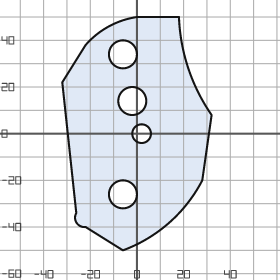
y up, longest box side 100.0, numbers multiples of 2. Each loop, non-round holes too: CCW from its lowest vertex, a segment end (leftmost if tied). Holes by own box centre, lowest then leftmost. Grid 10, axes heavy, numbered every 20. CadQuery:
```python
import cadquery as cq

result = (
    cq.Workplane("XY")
    .moveTo(-6.0, -50.0)
    .threePointArc((14.0, -38.0), (28.0, -20.0))
    .lineTo(32.0, 8.0)
    .threePointArc((22.0, 28.0), (18.0, 50.0))
    .lineTo(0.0, 50.0)
    .threePointArc((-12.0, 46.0), (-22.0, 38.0))
    .lineTo(-32.0, 22.0)
    .lineTo(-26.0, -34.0)
    .threePointArc((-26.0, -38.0), (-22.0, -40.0))
    .close()
    .moveTo(-6.0, -26.0)
    .circle(6.0)
    .moveTo(2.0, 0.0)
    .circle(4.0)
    .moveTo(-2.0, 14.0)
    .circle(6.0)
    .moveTo(-6.0, 34.0)
    .circle(6.0)
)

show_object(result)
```